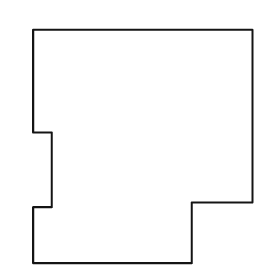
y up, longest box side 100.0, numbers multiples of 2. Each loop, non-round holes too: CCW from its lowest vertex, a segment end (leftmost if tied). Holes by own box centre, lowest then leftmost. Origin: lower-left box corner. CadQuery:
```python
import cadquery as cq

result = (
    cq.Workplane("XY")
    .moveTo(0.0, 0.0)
    .lineTo(68.0, 0.0)
    .lineTo(68.0, 26.0)
    .lineTo(94.0, 26.0)
    .lineTo(94.0, 100.0)
    .lineTo(0.0, 100.0)
    .lineTo(0.0, 56.0)
    .lineTo(8.0, 56.0)
    .lineTo(8.0, 24.0)
    .lineTo(0.0, 24.0)
    .close()
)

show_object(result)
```